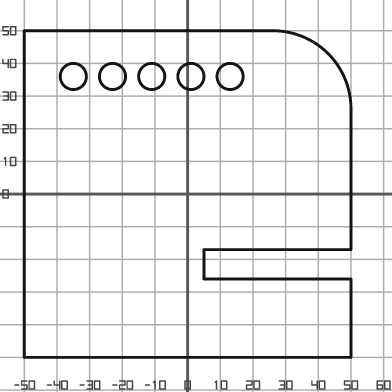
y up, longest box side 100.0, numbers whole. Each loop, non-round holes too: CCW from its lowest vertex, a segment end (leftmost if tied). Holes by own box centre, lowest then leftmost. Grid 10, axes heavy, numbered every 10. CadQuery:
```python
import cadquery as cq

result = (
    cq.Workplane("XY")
    .moveTo(-50.0, -50.0)
    .lineTo(50.0, -50.0)
    .lineTo(50.0, -26.0)
    .lineTo(5.0, -26.0)
    .lineTo(5.0, -17.0)
    .lineTo(50.0, -17.0)
    .lineTo(50.0, 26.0)
    .threePointArc((43.0, 43.0), (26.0, 50.0))
    .lineTo(-50.0, 50.0)
    .close()
    .moveTo(-35.0, 36.0)
    .circle(4.0)
    .moveTo(-23.0, 36.0)
    .circle(4.0)
    .moveTo(-11.0, 36.0)
    .circle(4.0)
    .moveTo(1.0, 36.0)
    .circle(4.0)
    .moveTo(13.0, 36.0)
    .circle(4.0)
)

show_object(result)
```